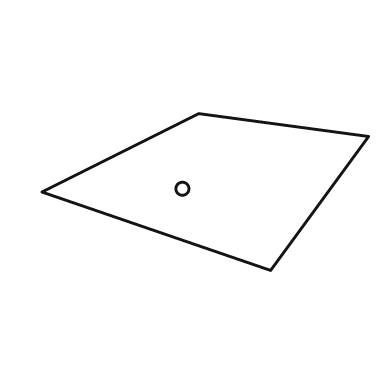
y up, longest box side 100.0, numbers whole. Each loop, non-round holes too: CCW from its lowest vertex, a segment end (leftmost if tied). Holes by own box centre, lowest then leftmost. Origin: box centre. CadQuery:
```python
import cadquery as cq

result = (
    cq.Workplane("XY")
    .moveTo(20.0, -24.0)
    .lineTo(50.0, 17.0)
    .lineTo(-2.0, 24.0)
    .lineTo(-50.0, 0.0)
    .close()
    .moveTo(-7.0, 1.0)
    .circle(2.0)
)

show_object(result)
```